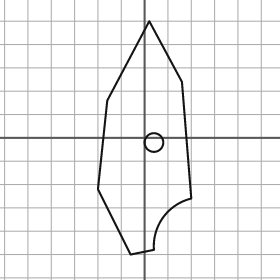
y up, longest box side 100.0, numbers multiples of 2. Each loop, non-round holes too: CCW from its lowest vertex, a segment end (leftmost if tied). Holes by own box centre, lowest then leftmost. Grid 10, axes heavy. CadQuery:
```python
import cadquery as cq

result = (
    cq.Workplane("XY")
    .moveTo(-6.0, -50.0)
    .lineTo(4.0, -48.0)
    .threePointArc((8.0, -34.0), (20.0, -26.0))
    .lineTo(16.0, 24.0)
    .lineTo(2.0, 50.0)
    .lineTo(-16.0, 16.0)
    .lineTo(-20.0, -22.0)
    .close()
    .moveTo(4.0, -2.0)
    .circle(4.0)
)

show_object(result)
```